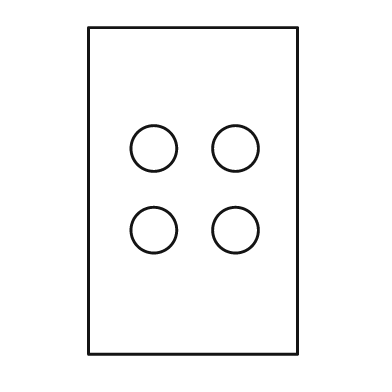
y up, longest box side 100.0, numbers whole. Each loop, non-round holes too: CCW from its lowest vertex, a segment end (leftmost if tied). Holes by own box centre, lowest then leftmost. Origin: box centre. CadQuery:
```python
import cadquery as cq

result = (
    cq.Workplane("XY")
    .moveTo(-32.0, -50.0)
    .lineTo(32.0, -50.0)
    .lineTo(32.0, 50.0)
    .lineTo(-32.0, 50.0)
    .close()
    .moveTo(-12.0, -12.0)
    .circle(7.0)
    .moveTo(13.0, -12.0)
    .circle(7.0)
    .moveTo(-12.0, 13.0)
    .circle(7.0)
    .moveTo(13.0, 13.0)
    .circle(7.0)
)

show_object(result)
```